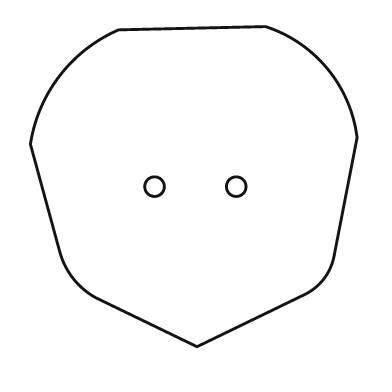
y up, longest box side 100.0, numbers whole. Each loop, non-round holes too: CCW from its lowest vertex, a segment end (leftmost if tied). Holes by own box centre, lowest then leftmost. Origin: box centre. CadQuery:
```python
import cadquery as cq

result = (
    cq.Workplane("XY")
    .moveTo(1.0, -49.0)
    .lineTo(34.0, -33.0)
    .threePointArc((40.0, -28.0), (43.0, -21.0))
    .lineTo(50.0, 15.0)
    .threePointArc((41.0, 36.0), (22.0, 49.0))
    .lineTo(-23.0, 48.0)
    .threePointArc((-41.0, 34.0), (-50.0, 13.0))
    .lineTo(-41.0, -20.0)
    .threePointArc((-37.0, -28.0), (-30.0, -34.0))
    .close()
    .moveTo(-12.0, 0.0)
    .circle(3.0)
    .moveTo(13.0, 0.0)
    .circle(3.0)
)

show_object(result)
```